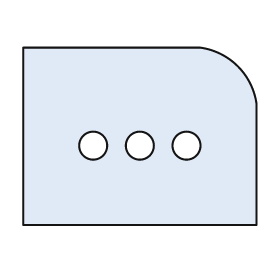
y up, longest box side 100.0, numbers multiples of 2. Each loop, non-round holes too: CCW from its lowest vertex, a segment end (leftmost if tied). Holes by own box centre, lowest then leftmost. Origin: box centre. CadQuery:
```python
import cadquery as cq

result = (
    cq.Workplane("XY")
    .moveTo(-50.0, -38.0)
    .lineTo(50.0, -38.0)
    .lineTo(50.0, 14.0)
    .threePointArc((42.0, 30.0), (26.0, 38.0))
    .lineTo(-50.0, 38.0)
    .close()
    .moveTo(-20.0, -4.0)
    .circle(6.0)
    .moveTo(0.0, -4.0)
    .circle(6.0)
    .moveTo(20.0, -4.0)
    .circle(6.0)
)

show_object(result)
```